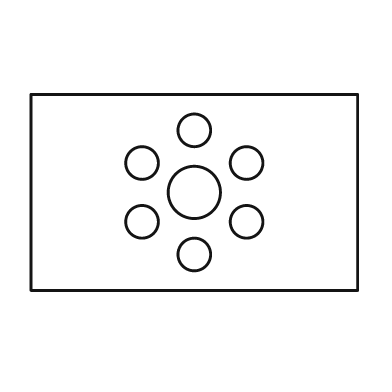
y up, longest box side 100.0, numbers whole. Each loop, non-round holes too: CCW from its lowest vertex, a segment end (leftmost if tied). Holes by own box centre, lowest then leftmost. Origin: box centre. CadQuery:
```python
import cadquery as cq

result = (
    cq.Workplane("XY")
    .moveTo(-50.0, -30.0)
    .lineTo(50.0, -30.0)
    .lineTo(50.0, 30.0)
    .lineTo(-50.0, 30.0)
    .close()
    .moveTo(0.0, -19.0)
    .circle(5.0)
    .moveTo(-16.0, -9.0)
    .circle(5.0)
    .moveTo(16.0, -9.0)
    .circle(5.0)
    .moveTo(0.0, 0.0)
    .circle(8.0)
    .moveTo(-16.0, 9.0)
    .circle(5.0)
    .moveTo(16.0, 9.0)
    .circle(5.0)
    .moveTo(0.0, 19.0)
    .circle(5.0)
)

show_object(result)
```